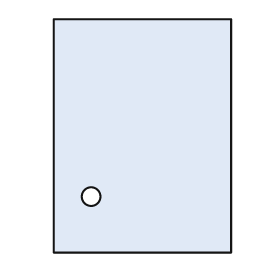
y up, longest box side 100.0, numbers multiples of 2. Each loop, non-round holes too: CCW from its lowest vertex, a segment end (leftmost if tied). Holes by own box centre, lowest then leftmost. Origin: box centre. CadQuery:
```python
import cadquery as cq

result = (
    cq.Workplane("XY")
    .moveTo(-38.0, -50.0)
    .lineTo(38.0, -50.0)
    .lineTo(38.0, 50.0)
    .lineTo(-38.0, 50.0)
    .close()
    .moveTo(-22.0, -26.0)
    .circle(4.0)
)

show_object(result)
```